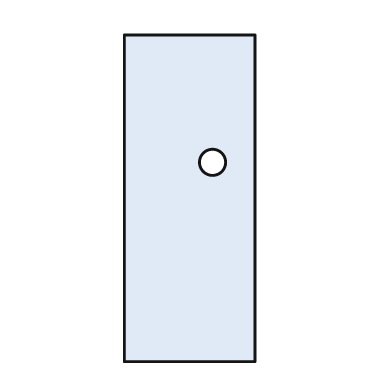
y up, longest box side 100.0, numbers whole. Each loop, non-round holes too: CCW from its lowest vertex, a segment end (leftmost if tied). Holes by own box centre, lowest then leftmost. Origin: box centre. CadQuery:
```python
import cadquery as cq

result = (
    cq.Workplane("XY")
    .moveTo(-20.0, -50.0)
    .lineTo(20.0, -50.0)
    .lineTo(20.0, 50.0)
    .lineTo(-20.0, 50.0)
    .close()
    .moveTo(7.0, 11.0)
    .circle(4.0)
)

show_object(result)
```